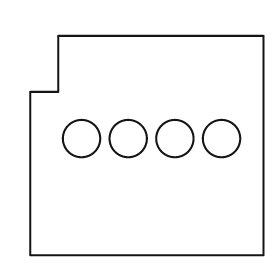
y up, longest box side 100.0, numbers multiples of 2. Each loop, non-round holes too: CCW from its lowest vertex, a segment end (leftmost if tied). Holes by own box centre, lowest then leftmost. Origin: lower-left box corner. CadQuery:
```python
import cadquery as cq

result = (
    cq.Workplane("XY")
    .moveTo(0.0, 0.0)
    .lineTo(100.0, 0.0)
    .lineTo(100.0, 94.0)
    .lineTo(12.0, 94.0)
    .lineTo(12.0, 70.0)
    .lineTo(0.0, 70.0)
    .close()
    .moveTo(22.0, 50.0)
    .circle(8.0)
    .moveTo(42.0, 50.0)
    .circle(8.0)
    .moveTo(62.0, 50.0)
    .circle(8.0)
    .moveTo(82.0, 50.0)
    .circle(8.0)
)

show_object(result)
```